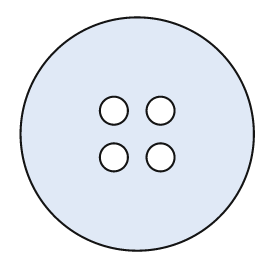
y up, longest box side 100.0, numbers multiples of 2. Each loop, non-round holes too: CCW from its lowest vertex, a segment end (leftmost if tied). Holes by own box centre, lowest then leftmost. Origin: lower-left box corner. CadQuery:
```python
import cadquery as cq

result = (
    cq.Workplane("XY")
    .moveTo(50.0, 50.0)
    .circle(50.0)
    .moveTo(40.0, 40.0)
    .circle(6.0)
    .moveTo(60.0, 40.0)
    .circle(6.0)
    .moveTo(40.0, 60.0)
    .circle(6.0)
    .moveTo(60.0, 60.0)
    .circle(6.0)
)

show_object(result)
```